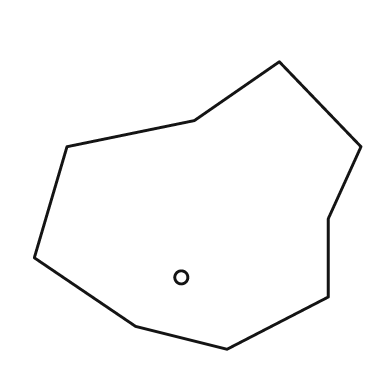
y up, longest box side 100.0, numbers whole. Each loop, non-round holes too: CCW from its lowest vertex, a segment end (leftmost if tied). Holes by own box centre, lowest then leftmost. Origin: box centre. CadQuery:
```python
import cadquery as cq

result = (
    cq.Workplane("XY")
    .moveTo(9.0, -44.0)
    .lineTo(40.0, -28.0)
    .lineTo(40.0, -4.0)
    .lineTo(50.0, 18.0)
    .lineTo(25.0, 44.0)
    .lineTo(-1.0, 26.0)
    .lineTo(-40.0, 18.0)
    .lineTo(-50.0, -16.0)
    .lineTo(-19.0, -37.0)
    .close()
    .moveTo(-5.0, -22.0)
    .circle(2.0)
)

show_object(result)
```